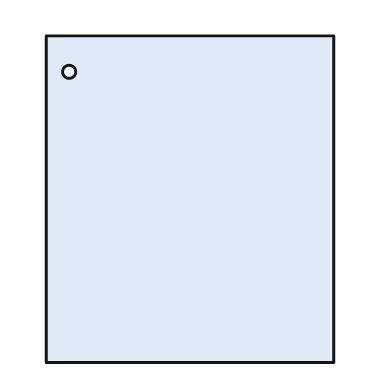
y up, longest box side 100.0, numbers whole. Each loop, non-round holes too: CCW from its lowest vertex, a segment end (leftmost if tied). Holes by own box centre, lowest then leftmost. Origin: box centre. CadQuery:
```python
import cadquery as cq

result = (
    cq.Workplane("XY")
    .moveTo(-44.0, -50.0)
    .lineTo(44.0, -50.0)
    .lineTo(44.0, 50.0)
    .lineTo(-44.0, 50.0)
    .close()
    .moveTo(-37.0, 39.0)
    .circle(2.0)
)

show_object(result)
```